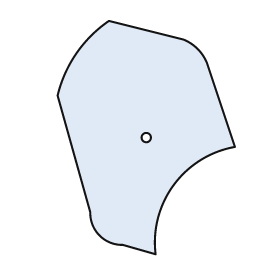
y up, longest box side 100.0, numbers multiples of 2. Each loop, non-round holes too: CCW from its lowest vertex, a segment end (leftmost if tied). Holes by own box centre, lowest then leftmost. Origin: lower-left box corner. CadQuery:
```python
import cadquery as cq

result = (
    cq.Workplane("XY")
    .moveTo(42.0, 0.0)
    .threePointArc((50.0, 30.0), (76.0, 46.0))
    .lineTo(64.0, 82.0)
    .threePointArc((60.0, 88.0), (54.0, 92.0))
    .lineTo(22.0, 100.0)
    .threePointArc((8.0, 86.0), (0.0, 68.0))
    .lineTo(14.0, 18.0)
    .threePointArc((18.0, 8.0), (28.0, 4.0))
    .close()
    .moveTo(38.0, 50.0)
    .circle(2.0)
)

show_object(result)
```